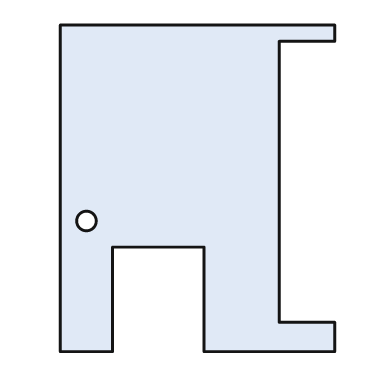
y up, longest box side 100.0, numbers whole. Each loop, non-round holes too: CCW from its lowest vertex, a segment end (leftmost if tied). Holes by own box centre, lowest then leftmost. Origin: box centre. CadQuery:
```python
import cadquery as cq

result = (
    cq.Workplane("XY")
    .moveTo(-42.0, -50.0)
    .lineTo(-26.0, -50.0)
    .lineTo(-26.0, -18.0)
    .lineTo(2.0, -18.0)
    .lineTo(2.0, -50.0)
    .lineTo(42.0, -50.0)
    .lineTo(42.0, -41.0)
    .lineTo(25.0, -41.0)
    .lineTo(25.0, 45.0)
    .lineTo(42.0, 45.0)
    .lineTo(42.0, 50.0)
    .lineTo(-42.0, 50.0)
    .close()
    .moveTo(-34.0, -10.0)
    .circle(3.0)
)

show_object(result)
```